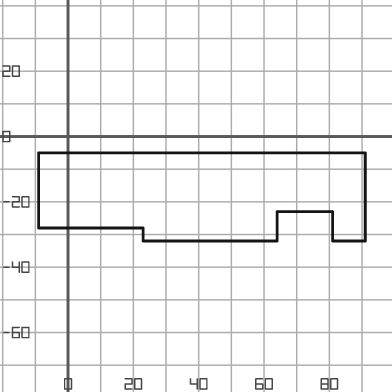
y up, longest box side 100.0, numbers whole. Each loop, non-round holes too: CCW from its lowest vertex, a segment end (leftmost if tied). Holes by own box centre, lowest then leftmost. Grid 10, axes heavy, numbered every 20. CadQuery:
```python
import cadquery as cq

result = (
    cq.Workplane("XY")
    .moveTo(23.0, -32.0)
    .lineTo(64.0, -32.0)
    .lineTo(64.0, -23.0)
    .lineTo(81.0, -23.0)
    .lineTo(81.0, -32.0)
    .lineTo(91.0, -32.0)
    .lineTo(91.0, -5.0)
    .lineTo(-9.0, -5.0)
    .lineTo(-9.0, -28.0)
    .lineTo(23.0, -28.0)
    .close()
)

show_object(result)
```